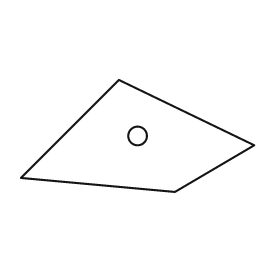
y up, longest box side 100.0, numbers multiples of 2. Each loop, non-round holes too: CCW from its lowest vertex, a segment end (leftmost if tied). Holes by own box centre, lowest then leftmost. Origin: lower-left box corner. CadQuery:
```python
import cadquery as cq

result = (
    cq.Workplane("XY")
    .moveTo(66.0, 0.0)
    .lineTo(100.0, 20.0)
    .lineTo(42.0, 48.0)
    .lineTo(0.0, 6.0)
    .close()
    .moveTo(50.0, 24.0)
    .circle(4.0)
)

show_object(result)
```